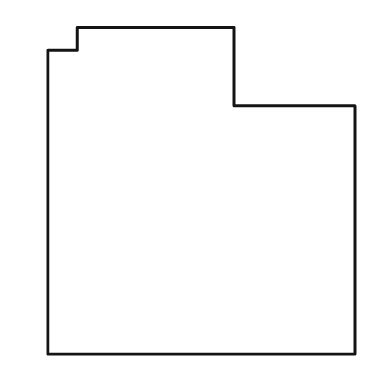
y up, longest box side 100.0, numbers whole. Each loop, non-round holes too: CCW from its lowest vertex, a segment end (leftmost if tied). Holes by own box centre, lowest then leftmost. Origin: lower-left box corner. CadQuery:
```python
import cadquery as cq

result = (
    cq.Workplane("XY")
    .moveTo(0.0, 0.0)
    .lineTo(94.0, 0.0)
    .lineTo(94.0, 76.0)
    .lineTo(57.0, 76.0)
    .lineTo(57.0, 100.0)
    .lineTo(9.0, 100.0)
    .lineTo(9.0, 93.0)
    .lineTo(0.0, 93.0)
    .close()
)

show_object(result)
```